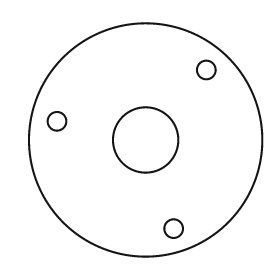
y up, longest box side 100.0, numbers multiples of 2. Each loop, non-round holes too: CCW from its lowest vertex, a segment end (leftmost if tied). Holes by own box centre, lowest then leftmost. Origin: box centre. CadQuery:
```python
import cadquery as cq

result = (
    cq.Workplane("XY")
    .moveTo(0.0, 0.0)
    .circle(50.0)
    .moveTo(12.0, -38.0)
    .circle(4.0)
    .moveTo(0.0, 0.0)
    .circle(14.0)
    .moveTo(-38.0, 8.0)
    .circle(4.0)
    .moveTo(26.0, 30.0)
    .circle(4.0)
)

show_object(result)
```